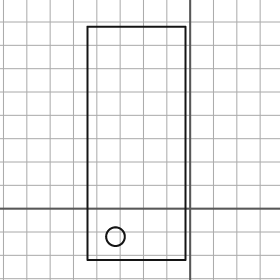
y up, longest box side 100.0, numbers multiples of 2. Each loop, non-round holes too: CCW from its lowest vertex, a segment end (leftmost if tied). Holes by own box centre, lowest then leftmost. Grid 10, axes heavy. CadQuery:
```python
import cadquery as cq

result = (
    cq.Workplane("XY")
    .moveTo(-44.0, -22.0)
    .lineTo(-2.0, -22.0)
    .lineTo(-2.0, 78.0)
    .lineTo(-44.0, 78.0)
    .close()
    .moveTo(-32.0, -12.0)
    .circle(4.0)
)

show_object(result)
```